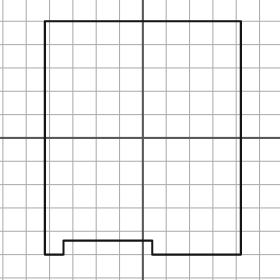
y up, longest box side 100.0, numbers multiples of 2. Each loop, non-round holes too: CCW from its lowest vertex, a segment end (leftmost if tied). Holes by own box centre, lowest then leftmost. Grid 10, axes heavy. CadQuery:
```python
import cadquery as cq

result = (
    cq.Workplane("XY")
    .moveTo(-42.0, -50.0)
    .lineTo(-34.0, -50.0)
    .lineTo(-34.0, -44.0)
    .lineTo(4.0, -44.0)
    .lineTo(4.0, -50.0)
    .lineTo(42.0, -50.0)
    .lineTo(42.0, 50.0)
    .lineTo(-42.0, 50.0)
    .close()
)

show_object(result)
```